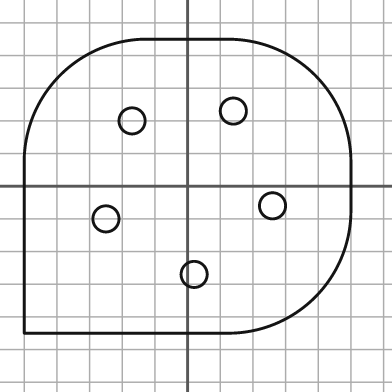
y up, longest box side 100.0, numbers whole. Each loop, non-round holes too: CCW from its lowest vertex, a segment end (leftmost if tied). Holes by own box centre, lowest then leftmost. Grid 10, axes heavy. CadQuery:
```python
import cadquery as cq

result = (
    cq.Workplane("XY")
    .moveTo(-50.0, -45.0)
    .lineTo(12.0, -45.0)
    .threePointArc((39.0, -34.0), (50.0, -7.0))
    .lineTo(50.0, 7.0)
    .threePointArc((39.0, 34.0), (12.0, 45.0))
    .lineTo(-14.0, 45.0)
    .threePointArc((-39.0, 34.0), (-50.0, 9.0))
    .close()
    .moveTo(2.0, -27.0)
    .circle(4.0)
    .moveTo(-25.0, -10.0)
    .circle(4.0)
    .moveTo(26.0, -6.0)
    .circle(4.0)
    .moveTo(-17.0, 20.0)
    .circle(4.0)
    .moveTo(14.0, 23.0)
    .circle(4.0)
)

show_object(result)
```